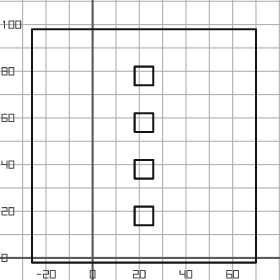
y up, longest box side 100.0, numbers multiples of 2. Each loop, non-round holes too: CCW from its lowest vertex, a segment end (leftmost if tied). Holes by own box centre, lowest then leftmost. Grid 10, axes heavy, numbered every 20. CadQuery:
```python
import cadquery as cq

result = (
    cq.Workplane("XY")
    .moveTo(-26.0, -2.0)
    .lineTo(70.0, -2.0)
    .lineTo(70.0, 98.0)
    .lineTo(-26.0, 98.0)
    .close()
    .moveTo(18.0, 14.0)
    .lineTo(26.0, 14.0)
    .lineTo(26.0, 22.0)
    .lineTo(18.0, 22.0)
    .close()
    .moveTo(18.0, 34.0)
    .lineTo(26.0, 34.0)
    .lineTo(26.0, 42.0)
    .lineTo(18.0, 42.0)
    .close()
    .moveTo(18.0, 54.0)
    .lineTo(26.0, 54.0)
    .lineTo(26.0, 62.0)
    .lineTo(18.0, 62.0)
    .close()
    .moveTo(18.0, 74.0)
    .lineTo(26.0, 74.0)
    .lineTo(26.0, 82.0)
    .lineTo(18.0, 82.0)
    .close()
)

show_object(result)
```